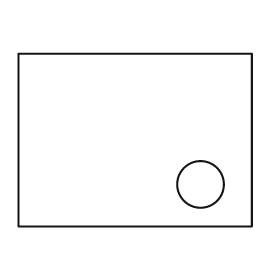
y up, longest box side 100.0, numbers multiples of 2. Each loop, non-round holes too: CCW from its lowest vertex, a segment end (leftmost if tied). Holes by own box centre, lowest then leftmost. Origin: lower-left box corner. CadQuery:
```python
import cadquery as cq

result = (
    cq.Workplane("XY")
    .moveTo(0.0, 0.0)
    .lineTo(100.0, 0.0)
    .lineTo(100.0, 74.0)
    .lineTo(0.0, 74.0)
    .close()
    .moveTo(78.0, 18.0)
    .circle(10.0)
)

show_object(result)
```